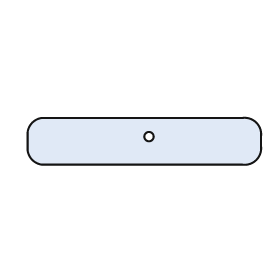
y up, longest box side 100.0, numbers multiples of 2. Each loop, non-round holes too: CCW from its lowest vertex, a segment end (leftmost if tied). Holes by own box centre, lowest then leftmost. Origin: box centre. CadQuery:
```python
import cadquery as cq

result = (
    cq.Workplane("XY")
    .moveTo(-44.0, -10.0)
    .lineTo(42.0, -10.0)
    .threePointArc((48.0, -8.0), (50.0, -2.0))
    .lineTo(50.0, 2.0)
    .threePointArc((48.0, 8.0), (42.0, 10.0))
    .lineTo(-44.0, 10.0)
    .threePointArc((-48.0, 8.0), (-50.0, 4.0))
    .lineTo(-50.0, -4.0)
    .threePointArc((-48.0, -8.0), (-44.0, -10.0))
    .close()
    .moveTo(2.0, 2.0)
    .circle(2.0)
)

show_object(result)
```